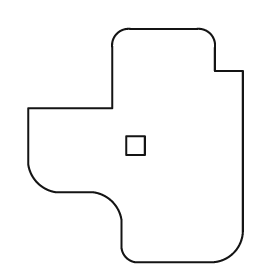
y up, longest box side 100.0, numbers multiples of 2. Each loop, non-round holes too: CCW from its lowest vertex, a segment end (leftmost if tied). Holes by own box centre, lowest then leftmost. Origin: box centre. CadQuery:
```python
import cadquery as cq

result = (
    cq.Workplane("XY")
    .moveTo(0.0, -50.0)
    .lineTo(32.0, -50.0)
    .threePointArc((42.0, -46.0), (46.0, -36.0))
    .lineTo(46.0, 32.0)
    .lineTo(34.0, 32.0)
    .lineTo(34.0, 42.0)
    .threePointArc((32.0, 48.0), (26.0, 50.0))
    .lineTo(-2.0, 50.0)
    .threePointArc((-8.0, 48.0), (-10.0, 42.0))
    .lineTo(-10.0, 16.0)
    .lineTo(-46.0, 16.0)
    .lineTo(-46.0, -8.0)
    .threePointArc((-42.0, -16.0), (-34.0, -20.0))
    .lineTo(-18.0, -20.0)
    .threePointArc((-10.0, -24.0), (-6.0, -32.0))
    .lineTo(-6.0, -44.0)
    .threePointArc((-4.0, -48.0), (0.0, -50.0))
    .close()
    .moveTo(-4.0, -4.0)
    .lineTo(4.0, -4.0)
    .lineTo(4.0, 4.0)
    .lineTo(-4.0, 4.0)
    .close()
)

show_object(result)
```